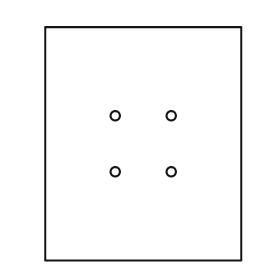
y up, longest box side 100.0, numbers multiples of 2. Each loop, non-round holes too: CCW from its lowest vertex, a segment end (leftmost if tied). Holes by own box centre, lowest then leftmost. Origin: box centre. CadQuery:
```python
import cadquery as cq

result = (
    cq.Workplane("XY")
    .moveTo(-42.0, -50.0)
    .lineTo(42.0, -50.0)
    .lineTo(42.0, 50.0)
    .lineTo(-42.0, 50.0)
    .close()
    .moveTo(-12.0, -12.0)
    .circle(2.0)
    .moveTo(12.0, -12.0)
    .circle(2.0)
    .moveTo(-12.0, 12.0)
    .circle(2.0)
    .moveTo(12.0, 12.0)
    .circle(2.0)
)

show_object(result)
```